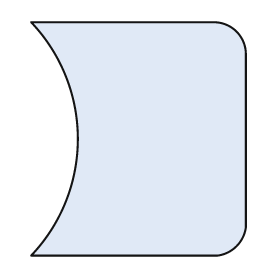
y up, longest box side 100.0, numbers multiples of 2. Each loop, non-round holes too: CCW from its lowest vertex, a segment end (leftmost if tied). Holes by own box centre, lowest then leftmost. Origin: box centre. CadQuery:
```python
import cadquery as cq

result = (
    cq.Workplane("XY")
    .moveTo(-46.0, -50.0)
    .lineTo(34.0, -50.0)
    .threePointArc((42.0, -46.0), (46.0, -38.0))
    .lineTo(46.0, 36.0)
    .threePointArc((42.0, 46.0), (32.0, 50.0))
    .lineTo(-46.0, 50.0)
    .threePointArc((-26.0, 0.0), (-46.0, -50.0))
    .close()
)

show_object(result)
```